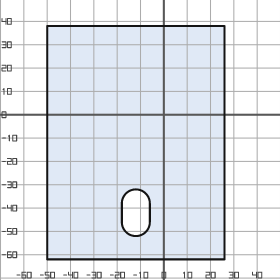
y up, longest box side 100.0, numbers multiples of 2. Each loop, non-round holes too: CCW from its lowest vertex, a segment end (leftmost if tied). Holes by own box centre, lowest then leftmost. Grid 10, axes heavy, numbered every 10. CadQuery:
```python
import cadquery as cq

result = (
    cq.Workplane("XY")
    .moveTo(-50.0, -62.0)
    .lineTo(26.0, -62.0)
    .lineTo(26.0, 38.0)
    .lineTo(-50.0, 38.0)
    .close()
    .moveTo(-18.0, -46.0)
    .threePointArc((-12.0, -52.0), (-6.0, -46.0))
    .lineTo(-6.0, -38.0)
    .threePointArc((-12.0, -32.0), (-18.0, -38.0))
    .close()
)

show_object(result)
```